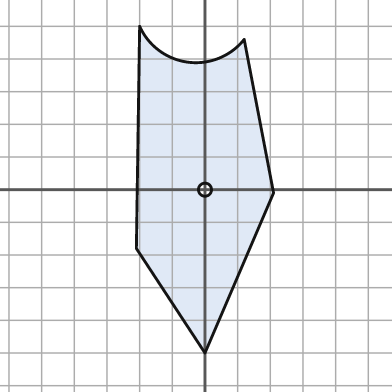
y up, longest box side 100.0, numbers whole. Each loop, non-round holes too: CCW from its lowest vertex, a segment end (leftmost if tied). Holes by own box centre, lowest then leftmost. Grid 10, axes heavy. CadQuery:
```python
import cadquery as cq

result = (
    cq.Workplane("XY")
    .moveTo(0.0, -50.0)
    .lineTo(21.0, -1.0)
    .lineTo(12.0, 46.0)
    .threePointArc((-5.0, 39.0), (-20.0, 50.0))
    .lineTo(-21.0, -18.0)
    .close()
    .moveTo(0.0, 0.0)
    .circle(2.0)
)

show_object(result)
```